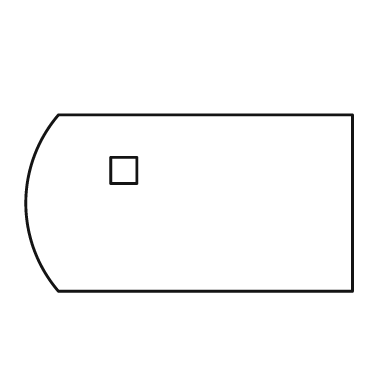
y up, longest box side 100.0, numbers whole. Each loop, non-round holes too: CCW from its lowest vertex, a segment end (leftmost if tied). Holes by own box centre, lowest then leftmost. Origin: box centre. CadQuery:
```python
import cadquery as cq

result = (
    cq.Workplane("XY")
    .moveTo(-40.0, -27.0)
    .lineTo(50.0, -27.0)
    .lineTo(50.0, 27.0)
    .lineTo(-40.0, 27.0)
    .threePointArc((-50.0, 0.0), (-40.0, -27.0))
    .close()
    .moveTo(-24.0, 6.0)
    .lineTo(-16.0, 6.0)
    .lineTo(-16.0, 14.0)
    .lineTo(-24.0, 14.0)
    .close()
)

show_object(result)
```